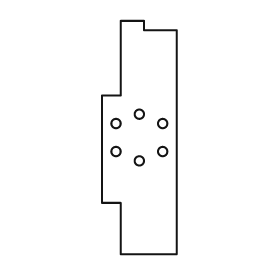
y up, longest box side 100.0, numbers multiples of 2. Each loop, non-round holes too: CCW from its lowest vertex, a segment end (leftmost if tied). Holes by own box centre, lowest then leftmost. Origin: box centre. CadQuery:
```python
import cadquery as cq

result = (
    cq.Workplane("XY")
    .moveTo(-8.0, -50.0)
    .lineTo(16.0, -50.0)
    .lineTo(16.0, 46.0)
    .lineTo(2.0, 46.0)
    .lineTo(2.0, 50.0)
    .lineTo(-8.0, 50.0)
    .lineTo(-8.0, 18.0)
    .lineTo(-16.0, 18.0)
    .lineTo(-16.0, -28.0)
    .lineTo(-8.0, -28.0)
    .close()
    .moveTo(0.0, -10.0)
    .circle(2.0)
    .moveTo(-10.0, -6.0)
    .circle(2.0)
    .moveTo(10.0, -6.0)
    .circle(2.0)
    .moveTo(-10.0, 6.0)
    .circle(2.0)
    .moveTo(10.0, 6.0)
    .circle(2.0)
    .moveTo(0.0, 10.0)
    .circle(2.0)
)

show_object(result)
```